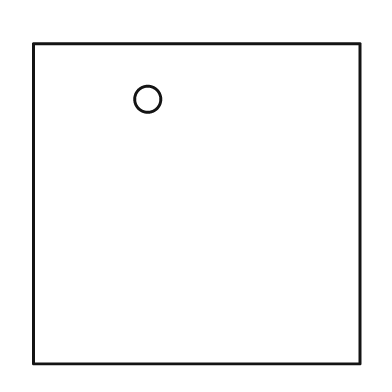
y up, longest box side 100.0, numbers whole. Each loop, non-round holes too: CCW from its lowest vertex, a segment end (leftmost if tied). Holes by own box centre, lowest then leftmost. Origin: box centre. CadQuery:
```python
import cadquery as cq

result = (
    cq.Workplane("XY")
    .moveTo(-50.0, -49.0)
    .lineTo(50.0, -49.0)
    .lineTo(50.0, 49.0)
    .lineTo(-50.0, 49.0)
    .close()
    .moveTo(-15.0, 32.0)
    .circle(4.0)
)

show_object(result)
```